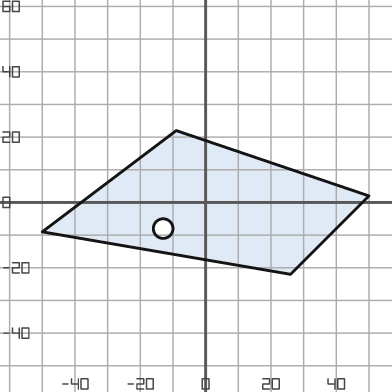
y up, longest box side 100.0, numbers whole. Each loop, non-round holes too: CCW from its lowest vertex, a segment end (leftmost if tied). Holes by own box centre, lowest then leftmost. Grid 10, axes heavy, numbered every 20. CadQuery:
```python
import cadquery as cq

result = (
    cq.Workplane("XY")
    .moveTo(26.0, -22.0)
    .lineTo(50.0, 2.0)
    .lineTo(-9.0, 22.0)
    .lineTo(-50.0, -9.0)
    .close()
    .moveTo(-13.0, -8.0)
    .circle(3.0)
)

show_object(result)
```